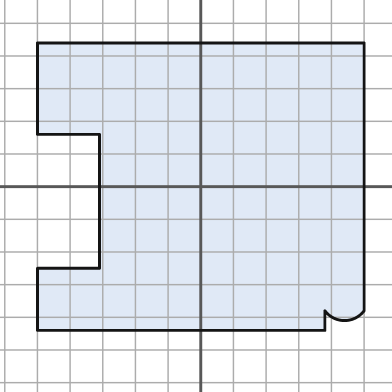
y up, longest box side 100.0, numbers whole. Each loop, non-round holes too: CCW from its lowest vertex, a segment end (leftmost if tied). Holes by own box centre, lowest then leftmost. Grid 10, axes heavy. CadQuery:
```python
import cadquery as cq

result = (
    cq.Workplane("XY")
    .moveTo(-50.0, -44.0)
    .lineTo(38.0, -44.0)
    .lineTo(38.0, -38.0)
    .threePointArc((44.0, -41.0), (50.0, -38.0))
    .lineTo(50.0, 44.0)
    .lineTo(-50.0, 44.0)
    .lineTo(-50.0, 16.0)
    .lineTo(-31.0, 16.0)
    .lineTo(-31.0, -25.0)
    .lineTo(-50.0, -25.0)
    .close()
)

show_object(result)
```